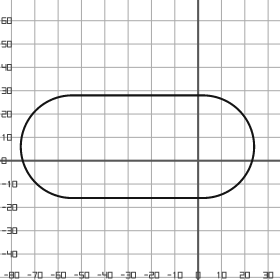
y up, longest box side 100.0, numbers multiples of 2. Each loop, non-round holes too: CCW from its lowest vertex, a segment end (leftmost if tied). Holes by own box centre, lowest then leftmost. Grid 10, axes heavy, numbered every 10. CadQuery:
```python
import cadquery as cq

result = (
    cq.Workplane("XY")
    .moveTo(-54.0, -16.0)
    .lineTo(2.0, -16.0)
    .threePointArc((24.0, 6.0), (2.0, 28.0))
    .lineTo(-54.0, 28.0)
    .threePointArc((-76.0, 6.0), (-54.0, -16.0))
    .close()
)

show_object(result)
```